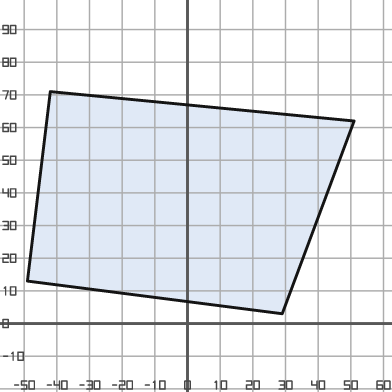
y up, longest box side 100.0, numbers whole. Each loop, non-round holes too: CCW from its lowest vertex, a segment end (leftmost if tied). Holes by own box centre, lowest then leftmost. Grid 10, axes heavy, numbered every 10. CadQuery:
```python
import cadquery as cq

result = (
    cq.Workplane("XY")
    .moveTo(29.0, 3.0)
    .lineTo(51.0, 62.0)
    .lineTo(-42.0, 71.0)
    .lineTo(-49.0, 13.0)
    .close()
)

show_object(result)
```